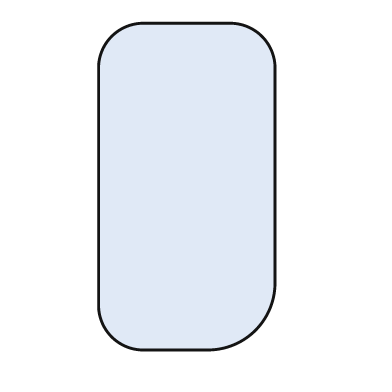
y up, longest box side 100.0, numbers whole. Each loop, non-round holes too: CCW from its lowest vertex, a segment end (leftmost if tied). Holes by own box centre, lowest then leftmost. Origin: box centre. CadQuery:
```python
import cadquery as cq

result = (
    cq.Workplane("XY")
    .moveTo(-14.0, -50.0)
    .lineTo(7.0, -50.0)
    .threePointArc((21.0, -44.0), (27.0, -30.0))
    .lineTo(27.0, 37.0)
    .threePointArc((23.0, 46.0), (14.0, 50.0))
    .lineTo(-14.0, 50.0)
    .threePointArc((-23.0, 46.0), (-27.0, 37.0))
    .lineTo(-27.0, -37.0)
    .threePointArc((-23.0, -46.0), (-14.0, -50.0))
    .close()
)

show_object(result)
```